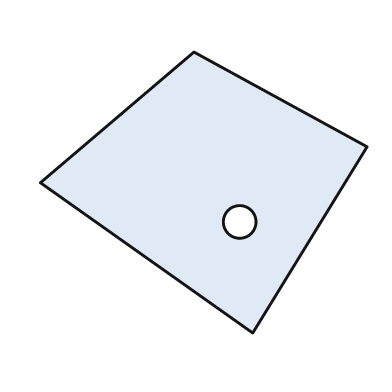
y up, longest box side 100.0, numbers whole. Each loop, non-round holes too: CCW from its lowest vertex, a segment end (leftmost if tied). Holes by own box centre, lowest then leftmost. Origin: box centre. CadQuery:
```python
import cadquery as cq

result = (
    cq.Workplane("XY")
    .moveTo(15.0, -43.0)
    .lineTo(50.0, 14.0)
    .lineTo(-3.0, 43.0)
    .lineTo(-50.0, 3.0)
    .close()
    .moveTo(11.0, -9.0)
    .circle(5.0)
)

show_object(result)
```